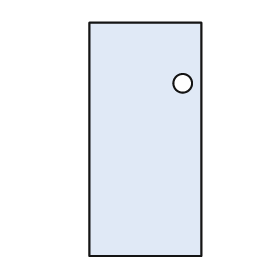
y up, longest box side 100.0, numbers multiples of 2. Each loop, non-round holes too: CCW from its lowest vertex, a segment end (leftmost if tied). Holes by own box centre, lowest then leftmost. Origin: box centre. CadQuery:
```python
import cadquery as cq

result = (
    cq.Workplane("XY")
    .moveTo(-24.0, -50.0)
    .lineTo(24.0, -50.0)
    .lineTo(24.0, 50.0)
    .lineTo(-24.0, 50.0)
    .close()
    .moveTo(16.0, 24.0)
    .circle(4.0)
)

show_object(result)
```